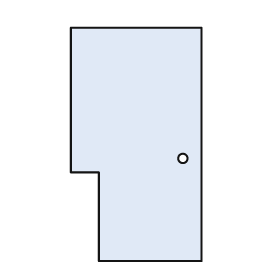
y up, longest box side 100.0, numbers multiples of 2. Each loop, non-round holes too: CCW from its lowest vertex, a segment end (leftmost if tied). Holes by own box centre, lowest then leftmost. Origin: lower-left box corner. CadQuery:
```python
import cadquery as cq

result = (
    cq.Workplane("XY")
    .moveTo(12.0, 0.0)
    .lineTo(56.0, 0.0)
    .lineTo(56.0, 100.0)
    .lineTo(0.0, 100.0)
    .lineTo(0.0, 38.0)
    .lineTo(12.0, 38.0)
    .close()
    .moveTo(48.0, 44.0)
    .circle(2.0)
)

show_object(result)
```